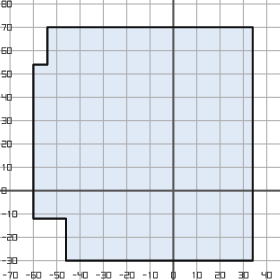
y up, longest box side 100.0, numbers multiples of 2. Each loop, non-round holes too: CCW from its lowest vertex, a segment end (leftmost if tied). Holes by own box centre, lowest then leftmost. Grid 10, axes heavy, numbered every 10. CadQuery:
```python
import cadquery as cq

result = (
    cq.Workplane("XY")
    .moveTo(-46.0, -30.0)
    .lineTo(34.0, -30.0)
    .lineTo(34.0, 70.0)
    .lineTo(-54.0, 70.0)
    .lineTo(-54.0, 54.0)
    .lineTo(-60.0, 54.0)
    .lineTo(-60.0, -12.0)
    .lineTo(-46.0, -12.0)
    .close()
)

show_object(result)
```